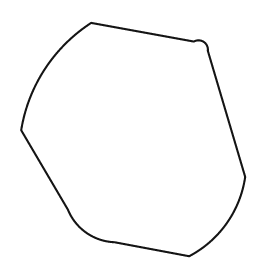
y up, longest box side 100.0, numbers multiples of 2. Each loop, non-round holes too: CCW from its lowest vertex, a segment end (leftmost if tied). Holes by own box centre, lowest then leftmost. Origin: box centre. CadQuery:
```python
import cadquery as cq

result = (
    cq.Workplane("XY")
    .moveTo(24.0, -50.0)
    .threePointArc((40.0, -36.0), (48.0, -16.0))
    .lineTo(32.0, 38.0)
    .threePointArc((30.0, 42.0), (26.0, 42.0))
    .lineTo(-18.0, 50.0)
    .threePointArc((-38.0, 30.0), (-48.0, 4.0))
    .lineTo(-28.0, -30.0)
    .threePointArc((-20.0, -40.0), (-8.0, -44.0))
    .close()
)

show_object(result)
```